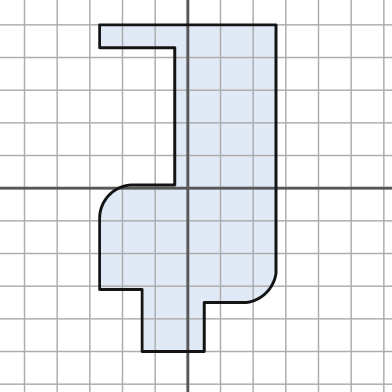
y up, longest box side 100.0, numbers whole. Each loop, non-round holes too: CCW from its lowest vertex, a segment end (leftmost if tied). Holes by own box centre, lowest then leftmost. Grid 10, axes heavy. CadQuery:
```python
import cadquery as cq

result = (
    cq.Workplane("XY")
    .moveTo(-14.0, -50.0)
    .lineTo(5.0, -50.0)
    .lineTo(5.0, -35.0)
    .lineTo(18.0, -35.0)
    .threePointArc((24.0, -32.0), (27.0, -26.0))
    .lineTo(27.0, 50.0)
    .lineTo(-27.0, 50.0)
    .lineTo(-27.0, 43.0)
    .lineTo(-4.0, 43.0)
    .lineTo(-4.0, 1.0)
    .lineTo(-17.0, 1.0)
    .threePointArc((-24.0, -2.0), (-27.0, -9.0))
    .lineTo(-27.0, -31.0)
    .lineTo(-14.0, -31.0)
    .close()
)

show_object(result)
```